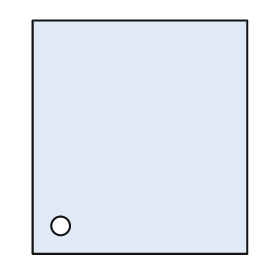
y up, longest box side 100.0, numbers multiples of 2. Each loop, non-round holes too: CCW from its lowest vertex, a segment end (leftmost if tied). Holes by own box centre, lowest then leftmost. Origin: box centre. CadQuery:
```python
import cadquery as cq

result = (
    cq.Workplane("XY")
    .moveTo(-46.0, -50.0)
    .lineTo(46.0, -50.0)
    .lineTo(46.0, 50.0)
    .lineTo(-46.0, 50.0)
    .close()
    .moveTo(-34.0, -38.0)
    .circle(4.0)
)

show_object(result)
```